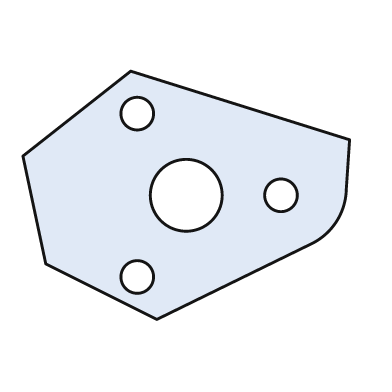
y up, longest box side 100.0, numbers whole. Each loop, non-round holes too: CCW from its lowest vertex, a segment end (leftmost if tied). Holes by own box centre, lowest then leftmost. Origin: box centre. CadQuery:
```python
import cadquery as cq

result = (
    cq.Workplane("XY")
    .moveTo(-9.0, -38.0)
    .lineTo(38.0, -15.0)
    .threePointArc((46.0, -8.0), (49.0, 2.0))
    .lineTo(50.0, 17.0)
    .lineTo(-17.0, 38.0)
    .lineTo(-50.0, 12.0)
    .lineTo(-43.0, -21.0)
    .close()
    .moveTo(-15.0, -25.0)
    .circle(5.0)
    .moveTo(0.0, 0.0)
    .circle(11.0)
    .moveTo(29.0, 0.0)
    .circle(5.0)
    .moveTo(-15.0, 25.0)
    .circle(5.0)
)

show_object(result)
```